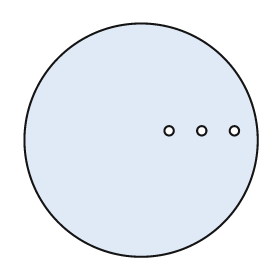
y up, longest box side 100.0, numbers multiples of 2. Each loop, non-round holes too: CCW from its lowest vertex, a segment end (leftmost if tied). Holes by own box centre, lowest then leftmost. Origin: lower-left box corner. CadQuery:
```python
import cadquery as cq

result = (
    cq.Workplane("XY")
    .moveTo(50.0, 50.0)
    .circle(50.0)
    .moveTo(62.0, 54.0)
    .circle(2.0)
    .moveTo(76.0, 54.0)
    .circle(2.0)
    .moveTo(90.0, 54.0)
    .circle(2.0)
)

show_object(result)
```